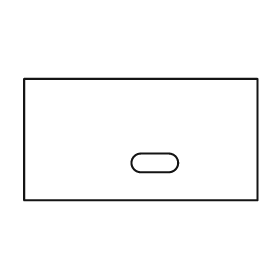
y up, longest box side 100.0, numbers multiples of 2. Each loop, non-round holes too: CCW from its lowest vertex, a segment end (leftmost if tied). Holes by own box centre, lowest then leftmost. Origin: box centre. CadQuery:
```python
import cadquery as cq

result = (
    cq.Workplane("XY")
    .moveTo(-50.0, -26.0)
    .lineTo(50.0, -26.0)
    .lineTo(50.0, 26.0)
    .lineTo(-50.0, 26.0)
    .close()
    .moveTo(0.0, -14.0)
    .lineTo(12.0, -14.0)
    .threePointArc((16.0, -10.0), (12.0, -6.0))
    .lineTo(0.0, -6.0)
    .threePointArc((-4.0, -10.0), (0.0, -14.0))
    .close()
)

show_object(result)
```